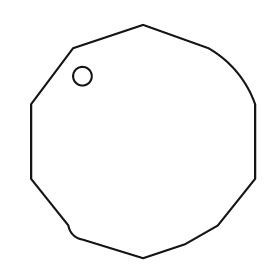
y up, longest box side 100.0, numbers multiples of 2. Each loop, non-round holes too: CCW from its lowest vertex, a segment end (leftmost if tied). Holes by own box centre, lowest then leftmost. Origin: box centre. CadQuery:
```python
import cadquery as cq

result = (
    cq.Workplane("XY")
    .moveTo(0.0, -50.0)
    .lineTo(18.0, -44.0)
    .lineTo(32.0, -36.0)
    .lineTo(48.0, -16.0)
    .lineTo(48.0, 16.0)
    .threePointArc((40.0, 30.0), (28.0, 40.0))
    .lineTo(0.0, 50.0)
    .lineTo(-30.0, 40.0)
    .lineTo(-48.0, 16.0)
    .lineTo(-48.0, -16.0)
    .lineTo(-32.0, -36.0)
    .threePointArc((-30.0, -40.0), (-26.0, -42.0))
    .close()
    .moveTo(-26.0, 28.0)
    .circle(4.0)
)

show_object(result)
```